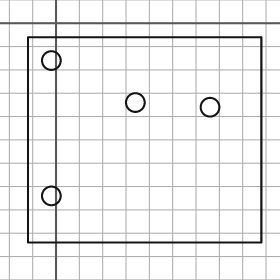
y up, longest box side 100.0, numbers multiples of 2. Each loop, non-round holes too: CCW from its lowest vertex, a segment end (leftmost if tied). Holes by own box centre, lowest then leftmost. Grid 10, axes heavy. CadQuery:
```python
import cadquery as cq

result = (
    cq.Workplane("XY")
    .moveTo(-12.0, -94.0)
    .lineTo(88.0, -94.0)
    .lineTo(88.0, -6.0)
    .lineTo(-12.0, -6.0)
    .close()
    .moveTo(-2.0, -74.0)
    .circle(4.0)
    .moveTo(66.0, -36.0)
    .circle(4.0)
    .moveTo(34.0, -34.0)
    .circle(4.0)
    .moveTo(-2.0, -16.0)
    .circle(4.0)
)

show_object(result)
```